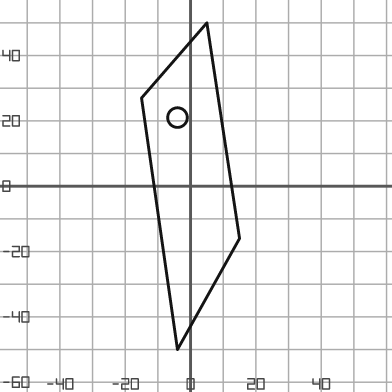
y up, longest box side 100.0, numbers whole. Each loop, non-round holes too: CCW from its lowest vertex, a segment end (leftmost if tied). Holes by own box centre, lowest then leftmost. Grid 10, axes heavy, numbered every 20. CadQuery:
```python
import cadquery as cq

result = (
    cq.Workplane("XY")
    .moveTo(-4.0, -50.0)
    .lineTo(15.0, -16.0)
    .lineTo(5.0, 50.0)
    .lineTo(-15.0, 27.0)
    .close()
    .moveTo(-4.0, 21.0)
    .circle(3.0)
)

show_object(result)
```